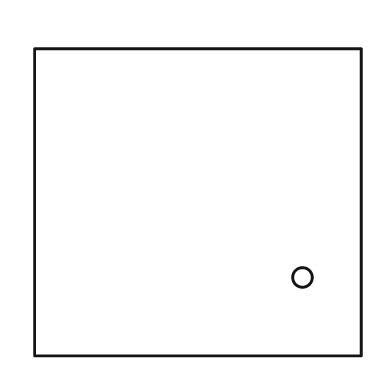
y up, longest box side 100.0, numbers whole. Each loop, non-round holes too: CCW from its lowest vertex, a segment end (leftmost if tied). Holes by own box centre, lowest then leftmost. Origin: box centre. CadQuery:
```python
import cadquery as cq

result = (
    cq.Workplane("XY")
    .moveTo(-50.0, -47.0)
    .lineTo(50.0, -47.0)
    .lineTo(50.0, 47.0)
    .lineTo(-50.0, 47.0)
    .close()
    .moveTo(32.0, -23.0)
    .circle(3.0)
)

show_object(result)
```